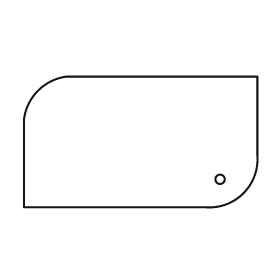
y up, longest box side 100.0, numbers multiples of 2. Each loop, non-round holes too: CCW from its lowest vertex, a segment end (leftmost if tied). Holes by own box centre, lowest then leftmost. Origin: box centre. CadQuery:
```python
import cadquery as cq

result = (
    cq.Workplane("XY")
    .moveTo(-50.0, -28.0)
    .lineTo(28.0, -28.0)
    .threePointArc((44.0, -22.0), (50.0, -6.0))
    .lineTo(50.0, 28.0)
    .lineTo(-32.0, 28.0)
    .threePointArc((-44.0, 22.0), (-50.0, 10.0))
    .close()
    .moveTo(34.0, -16.0)
    .circle(2.0)
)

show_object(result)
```